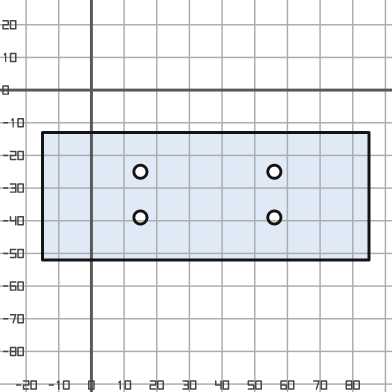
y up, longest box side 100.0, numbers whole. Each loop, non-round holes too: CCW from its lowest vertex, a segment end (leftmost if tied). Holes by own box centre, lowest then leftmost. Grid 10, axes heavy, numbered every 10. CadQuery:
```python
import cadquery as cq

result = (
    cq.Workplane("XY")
    .moveTo(-15.0, -52.0)
    .lineTo(85.0, -52.0)
    .lineTo(85.0, -13.0)
    .lineTo(-15.0, -13.0)
    .close()
    .moveTo(15.0, -39.0)
    .circle(2.0)
    .moveTo(56.0, -39.0)
    .circle(2.0)
    .moveTo(15.0, -25.0)
    .circle(2.0)
    .moveTo(56.0, -25.0)
    .circle(2.0)
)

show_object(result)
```